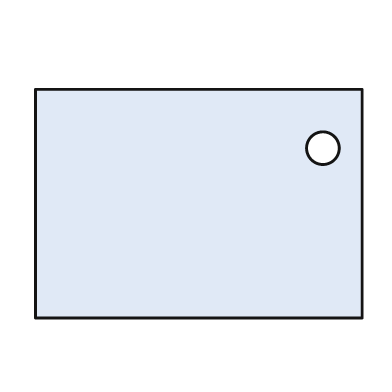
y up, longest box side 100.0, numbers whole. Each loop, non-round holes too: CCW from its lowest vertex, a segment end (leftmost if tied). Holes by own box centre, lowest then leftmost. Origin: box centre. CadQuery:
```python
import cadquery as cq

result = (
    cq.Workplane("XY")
    .moveTo(-50.0, -35.0)
    .lineTo(50.0, -35.0)
    .lineTo(50.0, 35.0)
    .lineTo(-50.0, 35.0)
    .close()
    .moveTo(38.0, 17.0)
    .circle(5.0)
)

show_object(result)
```